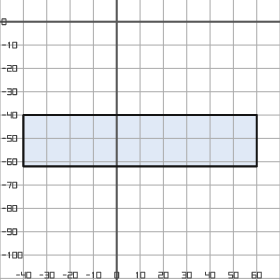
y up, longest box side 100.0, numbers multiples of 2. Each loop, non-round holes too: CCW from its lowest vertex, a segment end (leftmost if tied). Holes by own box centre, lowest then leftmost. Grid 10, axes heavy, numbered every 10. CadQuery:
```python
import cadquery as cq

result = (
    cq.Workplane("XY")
    .moveTo(-40.0, -62.0)
    .lineTo(60.0, -62.0)
    .lineTo(60.0, -40.0)
    .lineTo(-40.0, -40.0)
    .close()
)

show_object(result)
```